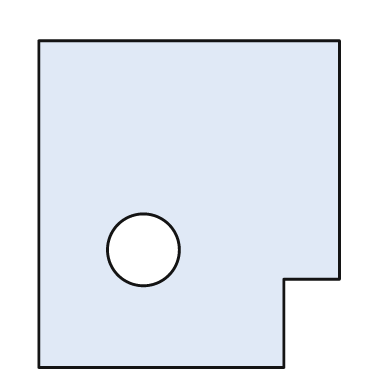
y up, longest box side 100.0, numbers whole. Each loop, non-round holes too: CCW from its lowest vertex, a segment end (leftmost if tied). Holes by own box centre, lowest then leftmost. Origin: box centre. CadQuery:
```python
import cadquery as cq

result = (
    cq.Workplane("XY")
    .moveTo(-46.0, -50.0)
    .lineTo(29.0, -50.0)
    .lineTo(29.0, -23.0)
    .lineTo(46.0, -23.0)
    .lineTo(46.0, 50.0)
    .lineTo(-46.0, 50.0)
    .close()
    .moveTo(-14.0, -14.0)
    .circle(11.0)
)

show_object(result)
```